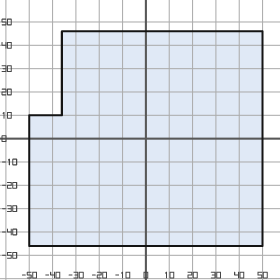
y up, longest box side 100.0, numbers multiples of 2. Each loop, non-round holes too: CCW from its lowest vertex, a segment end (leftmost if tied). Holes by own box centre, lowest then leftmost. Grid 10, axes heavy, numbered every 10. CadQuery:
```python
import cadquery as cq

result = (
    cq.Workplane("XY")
    .moveTo(-50.0, -46.0)
    .lineTo(50.0, -46.0)
    .lineTo(50.0, 46.0)
    .lineTo(-36.0, 46.0)
    .lineTo(-36.0, 10.0)
    .lineTo(-50.0, 10.0)
    .close()
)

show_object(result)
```